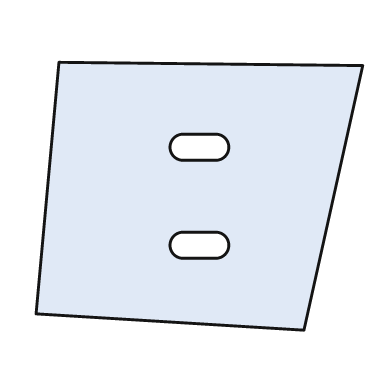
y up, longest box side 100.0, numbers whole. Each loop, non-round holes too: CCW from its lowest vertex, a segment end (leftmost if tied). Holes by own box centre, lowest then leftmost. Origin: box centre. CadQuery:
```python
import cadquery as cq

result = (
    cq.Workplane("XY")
    .moveTo(32.0, -41.0)
    .lineTo(50.0, 40.0)
    .lineTo(-43.0, 41.0)
    .lineTo(-50.0, -36.0)
    .close()
    .moveTo(-5.0, -19.0)
    .lineTo(5.0, -19.0)
    .threePointArc((9.0, -15.0), (5.0, -11.0))
    .lineTo(-5.0, -11.0)
    .threePointArc((-9.0, -15.0), (-5.0, -19.0))
    .close()
    .moveTo(-5.0, 11.0)
    .lineTo(5.0, 11.0)
    .threePointArc((9.0, 15.0), (5.0, 19.0))
    .lineTo(-5.0, 19.0)
    .threePointArc((-9.0, 15.0), (-5.0, 11.0))
    .close()
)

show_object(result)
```